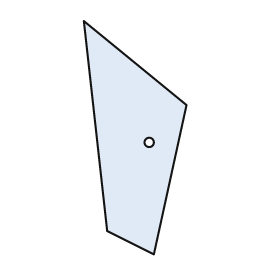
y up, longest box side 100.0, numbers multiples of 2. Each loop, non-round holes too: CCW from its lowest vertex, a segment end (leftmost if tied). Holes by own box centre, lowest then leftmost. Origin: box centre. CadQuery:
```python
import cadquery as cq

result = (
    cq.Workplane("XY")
    .moveTo(8.0, -50.0)
    .lineTo(22.0, 14.0)
    .lineTo(-22.0, 50.0)
    .lineTo(-12.0, -40.0)
    .close()
    .moveTo(6.0, -2.0)
    .circle(2.0)
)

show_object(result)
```